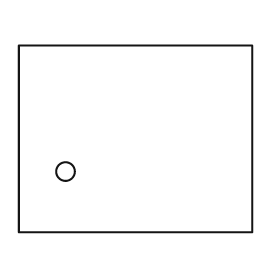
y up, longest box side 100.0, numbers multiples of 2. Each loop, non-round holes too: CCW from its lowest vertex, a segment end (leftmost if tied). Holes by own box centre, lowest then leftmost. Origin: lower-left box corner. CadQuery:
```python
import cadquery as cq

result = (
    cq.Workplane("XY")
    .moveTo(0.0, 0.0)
    .lineTo(100.0, 0.0)
    .lineTo(100.0, 80.0)
    .lineTo(0.0, 80.0)
    .close()
    .moveTo(20.0, 26.0)
    .circle(4.0)
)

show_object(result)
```